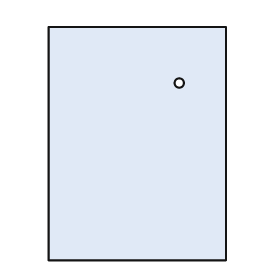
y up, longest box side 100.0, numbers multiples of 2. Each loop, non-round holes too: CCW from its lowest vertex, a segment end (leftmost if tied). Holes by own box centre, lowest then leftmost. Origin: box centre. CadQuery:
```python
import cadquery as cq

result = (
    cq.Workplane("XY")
    .moveTo(-38.0, -50.0)
    .lineTo(38.0, -50.0)
    .lineTo(38.0, 50.0)
    .lineTo(-38.0, 50.0)
    .close()
    .moveTo(18.0, 26.0)
    .circle(2.0)
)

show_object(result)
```